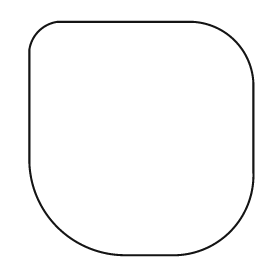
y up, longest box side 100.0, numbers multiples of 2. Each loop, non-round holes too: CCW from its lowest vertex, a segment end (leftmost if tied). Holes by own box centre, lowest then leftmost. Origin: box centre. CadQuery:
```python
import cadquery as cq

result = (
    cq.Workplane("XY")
    .moveTo(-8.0, -50.0)
    .lineTo(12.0, -50.0)
    .threePointArc((38.0, -40.0), (48.0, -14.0))
    .lineTo(48.0, 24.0)
    .threePointArc((40.0, 42.0), (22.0, 50.0))
    .lineTo(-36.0, 50.0)
    .threePointArc((-44.0, 46.0), (-48.0, 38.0))
    .lineTo(-48.0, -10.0)
    .threePointArc((-36.0, -38.0), (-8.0, -50.0))
    .close()
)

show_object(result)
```